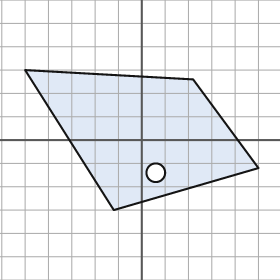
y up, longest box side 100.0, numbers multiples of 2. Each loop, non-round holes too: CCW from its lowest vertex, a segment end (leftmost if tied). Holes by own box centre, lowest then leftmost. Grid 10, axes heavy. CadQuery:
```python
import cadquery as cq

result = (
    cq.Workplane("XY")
    .moveTo(-12.0, -30.0)
    .lineTo(50.0, -12.0)
    .lineTo(22.0, 26.0)
    .lineTo(-50.0, 30.0)
    .close()
    .moveTo(6.0, -14.0)
    .circle(4.0)
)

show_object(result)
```